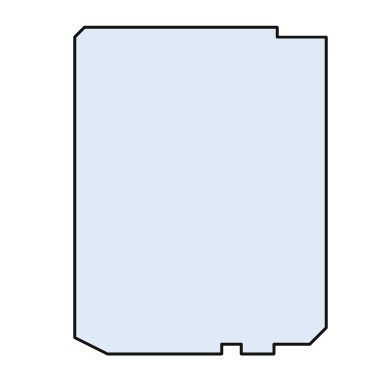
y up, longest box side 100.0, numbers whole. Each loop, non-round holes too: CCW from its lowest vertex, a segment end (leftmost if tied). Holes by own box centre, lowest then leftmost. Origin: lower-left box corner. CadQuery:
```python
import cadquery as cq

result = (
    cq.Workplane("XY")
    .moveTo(10.0, 0.0)
    .lineTo(45.0, 0.0)
    .lineTo(45.0, 3.0)
    .lineTo(51.0, 3.0)
    .lineTo(51.0, 0.0)
    .lineTo(61.0, 0.0)
    .lineTo(61.0, 3.0)
    .lineTo(72.0, 3.0)
    .lineTo(77.0, 8.0)
    .lineTo(77.0, 97.0)
    .lineTo(62.0, 97.0)
    .lineTo(62.0, 100.0)
    .lineTo(3.0, 100.0)
    .lineTo(0.0, 97.0)
    .lineTo(0.0, 5.0)
    .close()
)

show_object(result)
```